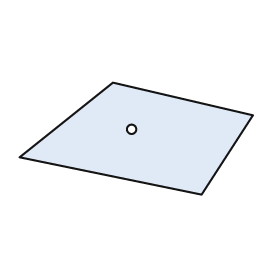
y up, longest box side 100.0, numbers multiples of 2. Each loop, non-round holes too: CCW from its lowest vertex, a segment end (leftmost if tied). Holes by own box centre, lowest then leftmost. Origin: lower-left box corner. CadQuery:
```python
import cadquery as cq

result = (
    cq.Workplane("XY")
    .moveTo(78.0, 0.0)
    .lineTo(100.0, 34.0)
    .lineTo(40.0, 48.0)
    .lineTo(0.0, 16.0)
    .close()
    .moveTo(48.0, 28.0)
    .circle(2.0)
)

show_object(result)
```